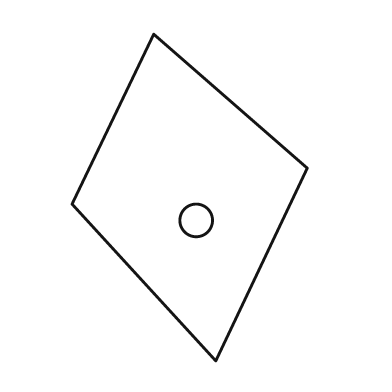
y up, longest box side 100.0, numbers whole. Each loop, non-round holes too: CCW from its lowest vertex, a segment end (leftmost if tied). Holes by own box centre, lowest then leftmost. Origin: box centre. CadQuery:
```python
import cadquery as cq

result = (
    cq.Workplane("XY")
    .moveTo(8.0, -50.0)
    .lineTo(36.0, 9.0)
    .lineTo(-11.0, 50.0)
    .lineTo(-36.0, -2.0)
    .close()
    .moveTo(2.0, -7.0)
    .circle(5.0)
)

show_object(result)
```